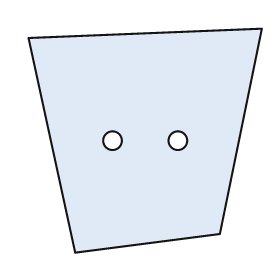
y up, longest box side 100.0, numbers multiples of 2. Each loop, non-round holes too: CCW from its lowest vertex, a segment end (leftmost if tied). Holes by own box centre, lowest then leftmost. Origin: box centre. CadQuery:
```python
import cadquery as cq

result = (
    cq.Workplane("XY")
    .moveTo(-30.0, -48.0)
    .lineTo(32.0, -40.0)
    .lineTo(50.0, 48.0)
    .lineTo(-50.0, 44.0)
    .close()
    .moveTo(-14.0, 0.0)
    .circle(4.0)
    .moveTo(14.0, 0.0)
    .circle(4.0)
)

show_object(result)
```